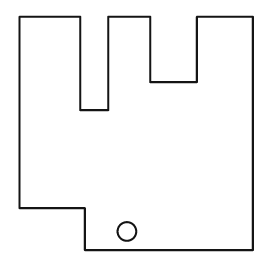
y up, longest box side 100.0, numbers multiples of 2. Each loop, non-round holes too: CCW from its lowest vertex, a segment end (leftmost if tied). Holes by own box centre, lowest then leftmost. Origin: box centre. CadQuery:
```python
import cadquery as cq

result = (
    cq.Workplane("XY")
    .moveTo(-22.0, -50.0)
    .lineTo(50.0, -50.0)
    .lineTo(50.0, 50.0)
    .lineTo(26.0, 50.0)
    .lineTo(26.0, 22.0)
    .lineTo(6.0, 22.0)
    .lineTo(6.0, 50.0)
    .lineTo(-12.0, 50.0)
    .lineTo(-12.0, 10.0)
    .lineTo(-24.0, 10.0)
    .lineTo(-24.0, 50.0)
    .lineTo(-50.0, 50.0)
    .lineTo(-50.0, -32.0)
    .lineTo(-22.0, -32.0)
    .close()
    .moveTo(-4.0, -42.0)
    .circle(4.0)
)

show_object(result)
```